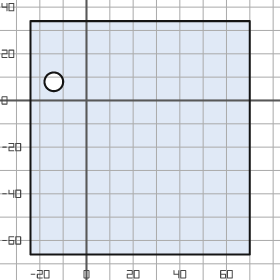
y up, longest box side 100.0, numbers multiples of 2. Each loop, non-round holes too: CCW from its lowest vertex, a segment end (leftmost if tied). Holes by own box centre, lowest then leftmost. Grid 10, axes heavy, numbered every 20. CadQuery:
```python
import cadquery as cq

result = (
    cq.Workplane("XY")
    .moveTo(-24.0, -66.0)
    .lineTo(70.0, -66.0)
    .lineTo(70.0, 34.0)
    .lineTo(-24.0, 34.0)
    .close()
    .moveTo(-14.0, 8.0)
    .circle(4.0)
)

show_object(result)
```